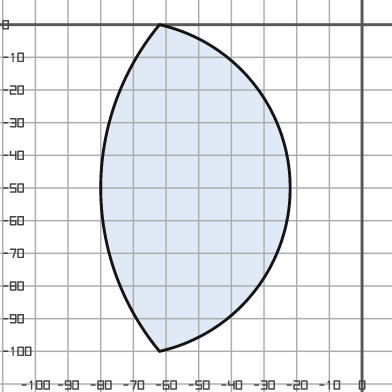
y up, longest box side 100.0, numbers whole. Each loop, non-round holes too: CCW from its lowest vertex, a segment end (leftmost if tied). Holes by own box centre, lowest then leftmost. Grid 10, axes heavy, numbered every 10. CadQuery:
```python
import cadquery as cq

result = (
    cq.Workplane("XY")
    .moveTo(-62.0, -100.0)
    .threePointArc((-22.0, -50.0), (-62.0, 0.0))
    .threePointArc((-80.0, -50.0), (-62.0, -100.0))
    .close()
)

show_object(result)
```